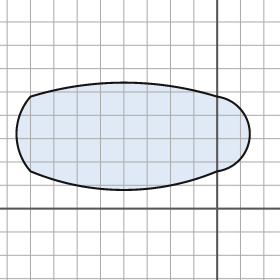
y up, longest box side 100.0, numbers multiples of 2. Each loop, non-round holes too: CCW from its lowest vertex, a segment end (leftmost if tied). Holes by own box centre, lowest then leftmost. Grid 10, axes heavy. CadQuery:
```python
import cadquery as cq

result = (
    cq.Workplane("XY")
    .moveTo(-80.0, 16.0)
    .threePointArc((-40.0, 8.0), (0.0, 16.0))
    .threePointArc((14.0, 32.0), (0.0, 48.0))
    .threePointArc((-40.0, 54.0), (-80.0, 48.0))
    .threePointArc((-86.0, 32.0), (-80.0, 16.0))
    .close()
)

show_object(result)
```